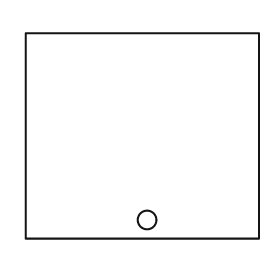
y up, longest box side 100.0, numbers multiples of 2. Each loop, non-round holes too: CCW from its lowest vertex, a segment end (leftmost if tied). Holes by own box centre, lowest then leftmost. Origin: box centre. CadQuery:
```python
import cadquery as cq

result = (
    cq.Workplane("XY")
    .moveTo(-50.0, -44.0)
    .lineTo(50.0, -44.0)
    .lineTo(50.0, 44.0)
    .lineTo(-50.0, 44.0)
    .close()
    .moveTo(2.0, -36.0)
    .circle(4.0)
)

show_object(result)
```